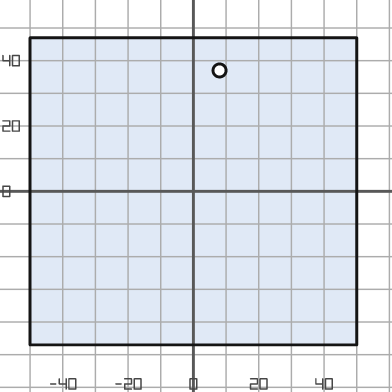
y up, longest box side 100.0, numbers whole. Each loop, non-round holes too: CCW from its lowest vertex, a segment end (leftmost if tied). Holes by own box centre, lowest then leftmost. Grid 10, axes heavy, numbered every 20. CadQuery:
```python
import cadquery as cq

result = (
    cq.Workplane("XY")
    .moveTo(-50.0, -47.0)
    .lineTo(50.0, -47.0)
    .lineTo(50.0, 47.0)
    .lineTo(-50.0, 47.0)
    .close()
    .moveTo(8.0, 37.0)
    .circle(2.0)
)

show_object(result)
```